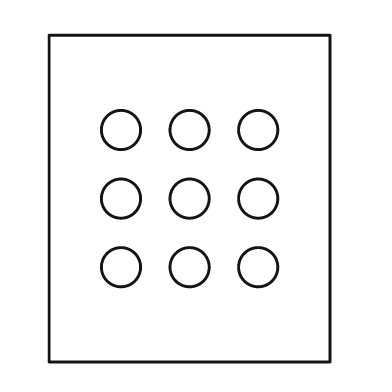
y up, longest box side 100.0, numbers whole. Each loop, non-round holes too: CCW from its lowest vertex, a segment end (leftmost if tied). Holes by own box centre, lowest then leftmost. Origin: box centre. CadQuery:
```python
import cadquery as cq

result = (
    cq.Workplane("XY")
    .moveTo(-43.0, -50.0)
    .lineTo(43.0, -50.0)
    .lineTo(43.0, 50.0)
    .lineTo(-43.0, 50.0)
    .close()
    .moveTo(-21.0, -21.0)
    .circle(6.0)
    .moveTo(0.0, -21.0)
    .circle(6.0)
    .moveTo(21.0, -21.0)
    .circle(6.0)
    .moveTo(-21.0, 0.0)
    .circle(6.0)
    .moveTo(0.0, 0.0)
    .circle(6.0)
    .moveTo(21.0, 0.0)
    .circle(6.0)
    .moveTo(-21.0, 21.0)
    .circle(6.0)
    .moveTo(0.0, 21.0)
    .circle(6.0)
    .moveTo(21.0, 21.0)
    .circle(6.0)
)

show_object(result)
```